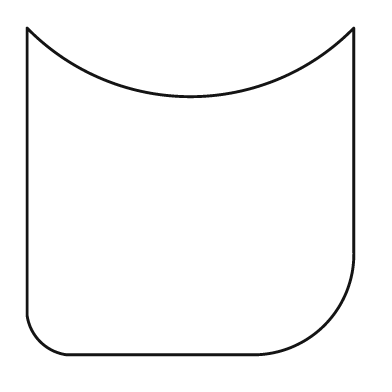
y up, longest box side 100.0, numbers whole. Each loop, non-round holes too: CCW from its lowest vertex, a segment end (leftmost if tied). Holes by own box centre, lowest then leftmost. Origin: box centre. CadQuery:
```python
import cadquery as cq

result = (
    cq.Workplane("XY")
    .moveTo(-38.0, -50.0)
    .lineTo(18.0, -50.0)
    .threePointArc((41.0, -41.0), (50.0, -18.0))
    .lineTo(50.0, 50.0)
    .threePointArc((0.0, 29.0), (-50.0, 50.0))
    .lineTo(-50.0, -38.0)
    .threePointArc((-46.0, -46.0), (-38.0, -50.0))
    .close()
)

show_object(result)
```